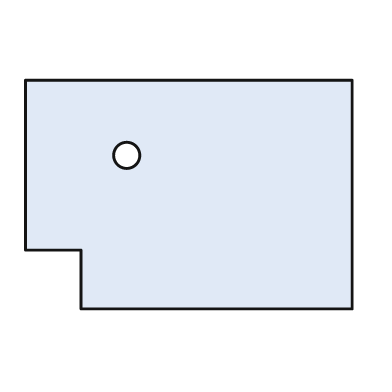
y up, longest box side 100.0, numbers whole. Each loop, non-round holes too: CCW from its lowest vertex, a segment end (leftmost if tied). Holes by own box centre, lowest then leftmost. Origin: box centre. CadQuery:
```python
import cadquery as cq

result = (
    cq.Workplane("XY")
    .moveTo(-33.0, -35.0)
    .lineTo(50.0, -35.0)
    .lineTo(50.0, 35.0)
    .lineTo(-50.0, 35.0)
    .lineTo(-50.0, -17.0)
    .lineTo(-33.0, -17.0)
    .close()
    .moveTo(-19.0, 12.0)
    .circle(4.0)
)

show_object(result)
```